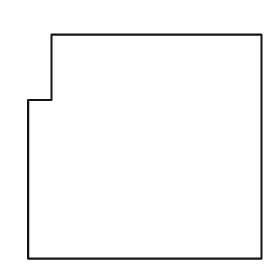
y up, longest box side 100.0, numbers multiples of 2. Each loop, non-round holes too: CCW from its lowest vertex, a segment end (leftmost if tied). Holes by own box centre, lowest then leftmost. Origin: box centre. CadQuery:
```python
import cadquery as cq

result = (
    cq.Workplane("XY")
    .moveTo(-50.0, -48.0)
    .lineTo(50.0, -48.0)
    .lineTo(50.0, 48.0)
    .lineTo(-40.0, 48.0)
    .lineTo(-40.0, 20.0)
    .lineTo(-50.0, 20.0)
    .close()
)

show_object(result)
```